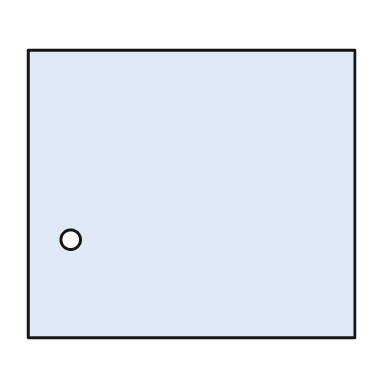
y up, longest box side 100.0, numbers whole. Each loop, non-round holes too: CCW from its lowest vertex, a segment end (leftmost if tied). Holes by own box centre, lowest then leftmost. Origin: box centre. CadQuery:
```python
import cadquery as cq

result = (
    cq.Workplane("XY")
    .moveTo(-50.0, -44.0)
    .lineTo(50.0, -44.0)
    .lineTo(50.0, 44.0)
    .lineTo(-50.0, 44.0)
    .close()
    .moveTo(-37.0, -14.0)
    .circle(3.0)
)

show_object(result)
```